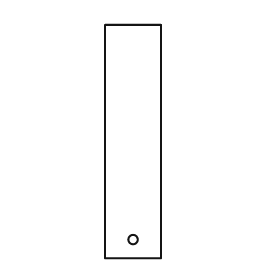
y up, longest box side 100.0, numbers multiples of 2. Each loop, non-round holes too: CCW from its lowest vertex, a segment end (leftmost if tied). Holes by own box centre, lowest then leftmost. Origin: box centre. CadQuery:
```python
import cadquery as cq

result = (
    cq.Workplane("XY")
    .moveTo(-12.0, -50.0)
    .lineTo(12.0, -50.0)
    .lineTo(12.0, 50.0)
    .lineTo(-12.0, 50.0)
    .close()
    .moveTo(0.0, -42.0)
    .circle(2.0)
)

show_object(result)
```